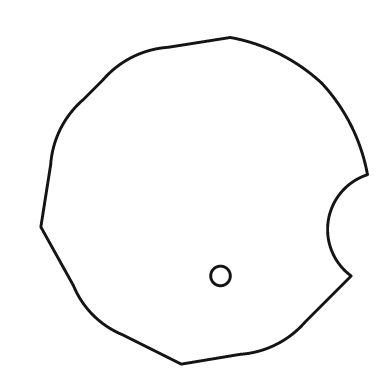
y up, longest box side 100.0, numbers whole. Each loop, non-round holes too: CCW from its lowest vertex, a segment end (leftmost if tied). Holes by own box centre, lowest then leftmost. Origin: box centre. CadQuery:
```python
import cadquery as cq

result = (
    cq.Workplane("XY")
    .moveTo(-7.0, -50.0)
    .lineTo(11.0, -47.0)
    .threePointArc((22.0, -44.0), (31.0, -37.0))
    .lineTo(45.0, -23.0)
    .threePointArc((38.0, -6.0), (50.0, 8.0))
    .threePointArc((45.0, 23.0), (36.0, 36.0))
    .threePointArc((23.0, 45.0), (8.0, 50.0))
    .lineTo(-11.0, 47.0)
    .threePointArc((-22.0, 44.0), (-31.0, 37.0))
    .lineTo(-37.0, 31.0)
    .threePointArc((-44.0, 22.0), (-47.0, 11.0))
    .lineTo(-50.0, -8.0)
    .lineTo(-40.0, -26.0)
    .threePointArc((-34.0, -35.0), (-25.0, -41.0))
    .close()
    .moveTo(5.0, -23.0)
    .circle(3.0)
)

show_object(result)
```